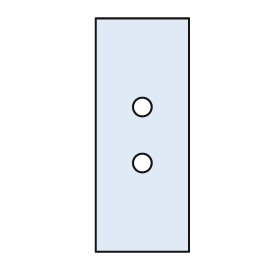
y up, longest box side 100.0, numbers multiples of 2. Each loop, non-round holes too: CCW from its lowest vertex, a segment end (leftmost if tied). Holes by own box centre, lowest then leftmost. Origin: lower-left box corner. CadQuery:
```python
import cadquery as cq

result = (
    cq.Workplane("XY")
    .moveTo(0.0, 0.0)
    .lineTo(40.0, 0.0)
    .lineTo(40.0, 100.0)
    .lineTo(0.0, 100.0)
    .close()
    .moveTo(20.0, 38.0)
    .circle(4.0)
    .moveTo(20.0, 62.0)
    .circle(4.0)
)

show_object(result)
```